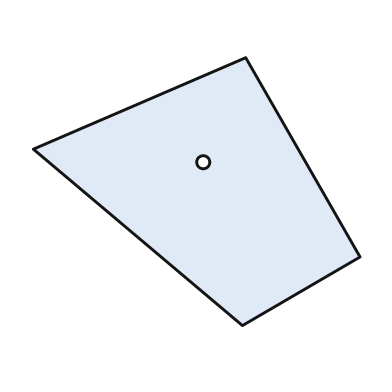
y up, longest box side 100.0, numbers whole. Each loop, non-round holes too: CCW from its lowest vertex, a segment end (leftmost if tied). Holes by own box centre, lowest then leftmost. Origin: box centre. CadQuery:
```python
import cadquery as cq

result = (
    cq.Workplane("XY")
    .moveTo(14.0, -41.0)
    .lineTo(50.0, -20.0)
    .lineTo(15.0, 41.0)
    .lineTo(-50.0, 13.0)
    .close()
    .moveTo(2.0, 9.0)
    .circle(2.0)
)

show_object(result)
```